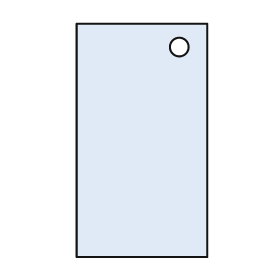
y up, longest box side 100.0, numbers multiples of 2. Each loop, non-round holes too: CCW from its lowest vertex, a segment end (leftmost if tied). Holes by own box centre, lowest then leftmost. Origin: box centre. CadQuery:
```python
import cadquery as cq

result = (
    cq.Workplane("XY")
    .moveTo(-28.0, -50.0)
    .lineTo(28.0, -50.0)
    .lineTo(28.0, 50.0)
    .lineTo(-28.0, 50.0)
    .close()
    .moveTo(16.0, 40.0)
    .circle(4.0)
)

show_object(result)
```